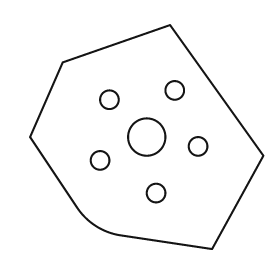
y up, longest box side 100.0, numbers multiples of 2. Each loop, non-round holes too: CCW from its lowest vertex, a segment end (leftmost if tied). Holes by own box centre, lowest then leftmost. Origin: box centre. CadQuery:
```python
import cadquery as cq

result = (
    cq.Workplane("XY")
    .moveTo(28.0, -48.0)
    .lineTo(50.0, -8.0)
    .lineTo(10.0, 48.0)
    .lineTo(-36.0, 32.0)
    .lineTo(-50.0, 0.0)
    .lineTo(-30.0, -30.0)
    .threePointArc((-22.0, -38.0), (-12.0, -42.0))
    .close()
    .moveTo(4.0, -24.0)
    .circle(4.0)
    .moveTo(-20.0, -10.0)
    .circle(4.0)
    .moveTo(22.0, -4.0)
    .circle(4.0)
    .moveTo(0.0, 0.0)
    .circle(8.0)
    .moveTo(-16.0, 16.0)
    .circle(4.0)
    .moveTo(12.0, 20.0)
    .circle(4.0)
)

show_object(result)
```